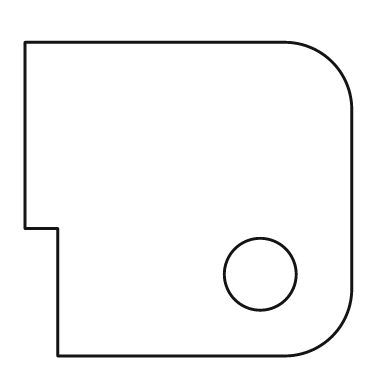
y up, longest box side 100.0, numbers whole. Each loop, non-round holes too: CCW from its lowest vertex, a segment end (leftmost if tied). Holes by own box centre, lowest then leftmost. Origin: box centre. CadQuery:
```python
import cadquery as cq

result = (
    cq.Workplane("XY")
    .moveTo(-40.0, -48.0)
    .lineTo(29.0, -48.0)
    .threePointArc((44.0, -42.0), (50.0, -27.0))
    .lineTo(50.0, 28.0)
    .threePointArc((44.0, 42.0), (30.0, 48.0))
    .lineTo(-50.0, 48.0)
    .lineTo(-50.0, -9.0)
    .lineTo(-40.0, -9.0)
    .close()
    .moveTo(22.0, -23.0)
    .circle(11.0)
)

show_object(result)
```